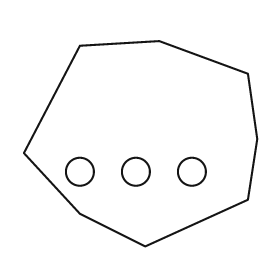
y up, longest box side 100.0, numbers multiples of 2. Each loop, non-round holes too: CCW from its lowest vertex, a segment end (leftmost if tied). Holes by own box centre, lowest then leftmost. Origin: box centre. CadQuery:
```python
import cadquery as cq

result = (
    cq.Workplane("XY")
    .moveTo(2.0, -44.0)
    .lineTo(46.0, -24.0)
    .lineTo(50.0, 2.0)
    .lineTo(46.0, 30.0)
    .lineTo(8.0, 44.0)
    .lineTo(-26.0, 42.0)
    .lineTo(-50.0, -4.0)
    .lineTo(-26.0, -30.0)
    .close()
    .moveTo(-26.0, -12.0)
    .circle(6.0)
    .moveTo(-2.0, -12.0)
    .circle(6.0)
    .moveTo(22.0, -12.0)
    .circle(6.0)
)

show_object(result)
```